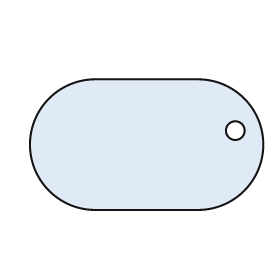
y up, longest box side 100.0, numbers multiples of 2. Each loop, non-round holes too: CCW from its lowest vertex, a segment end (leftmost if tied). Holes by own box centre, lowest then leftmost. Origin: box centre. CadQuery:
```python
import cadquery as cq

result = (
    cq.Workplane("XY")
    .moveTo(-22.0, -28.0)
    .lineTo(22.0, -28.0)
    .threePointArc((50.0, 0.0), (22.0, 28.0))
    .lineTo(-22.0, 28.0)
    .threePointArc((-50.0, 0.0), (-22.0, -28.0))
    .close()
    .moveTo(38.0, 6.0)
    .circle(4.0)
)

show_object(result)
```